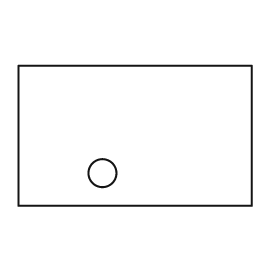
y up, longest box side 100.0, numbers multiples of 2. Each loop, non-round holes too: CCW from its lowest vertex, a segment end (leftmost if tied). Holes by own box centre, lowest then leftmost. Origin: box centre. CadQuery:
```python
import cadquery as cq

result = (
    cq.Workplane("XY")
    .moveTo(-50.0, -30.0)
    .lineTo(50.0, -30.0)
    .lineTo(50.0, 30.0)
    .lineTo(-50.0, 30.0)
    .close()
    .moveTo(-14.0, -16.0)
    .circle(6.0)
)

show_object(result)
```